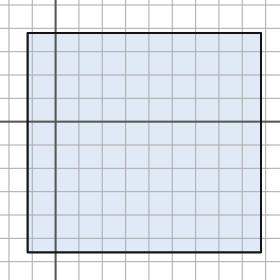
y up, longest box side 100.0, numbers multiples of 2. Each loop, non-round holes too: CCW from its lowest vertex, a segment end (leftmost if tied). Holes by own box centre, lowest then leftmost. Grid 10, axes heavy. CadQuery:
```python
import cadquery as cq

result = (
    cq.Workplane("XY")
    .moveTo(-12.0, -56.0)
    .lineTo(88.0, -56.0)
    .lineTo(88.0, 38.0)
    .lineTo(-12.0, 38.0)
    .close()
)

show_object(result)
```